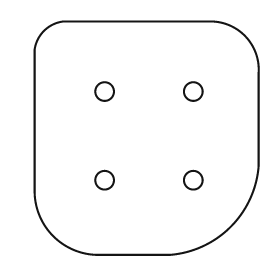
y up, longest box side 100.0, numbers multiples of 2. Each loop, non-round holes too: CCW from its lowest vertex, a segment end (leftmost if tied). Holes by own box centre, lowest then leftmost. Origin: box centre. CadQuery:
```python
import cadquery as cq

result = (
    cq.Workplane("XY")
    .moveTo(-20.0, -50.0)
    .lineTo(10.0, -50.0)
    .threePointArc((36.0, -38.0), (48.0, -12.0))
    .lineTo(48.0, 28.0)
    .threePointArc((42.0, 44.0), (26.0, 50.0))
    .lineTo(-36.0, 50.0)
    .threePointArc((-44.0, 46.0), (-48.0, 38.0))
    .lineTo(-48.0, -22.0)
    .threePointArc((-40.0, -42.0), (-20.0, -50.0))
    .close()
    .moveTo(-18.0, -18.0)
    .circle(4.0)
    .moveTo(20.0, -18.0)
    .circle(4.0)
    .moveTo(-18.0, 20.0)
    .circle(4.0)
    .moveTo(20.0, 20.0)
    .circle(4.0)
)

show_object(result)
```